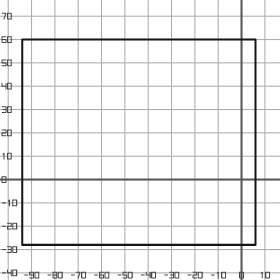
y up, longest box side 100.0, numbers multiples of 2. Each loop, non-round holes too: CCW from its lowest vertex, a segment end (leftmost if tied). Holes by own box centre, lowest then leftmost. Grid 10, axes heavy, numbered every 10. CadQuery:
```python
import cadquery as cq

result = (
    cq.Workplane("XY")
    .moveTo(-94.0, -28.0)
    .lineTo(6.0, -28.0)
    .lineTo(6.0, 60.0)
    .lineTo(-94.0, 60.0)
    .close()
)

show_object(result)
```